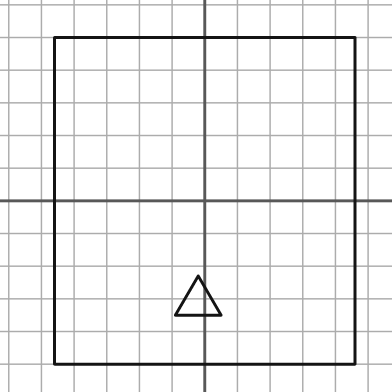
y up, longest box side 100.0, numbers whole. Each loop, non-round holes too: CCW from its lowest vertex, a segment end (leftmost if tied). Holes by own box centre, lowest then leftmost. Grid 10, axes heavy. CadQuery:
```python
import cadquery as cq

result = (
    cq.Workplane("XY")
    .moveTo(-46.0, -50.0)
    .lineTo(46.0, -50.0)
    .lineTo(46.0, 50.0)
    .lineTo(-46.0, 50.0)
    .close()
    .moveTo(-9.0, -35.0)
    .lineTo(5.0, -35.0)
    .lineTo(-2.0, -23.0)
    .close()
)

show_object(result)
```